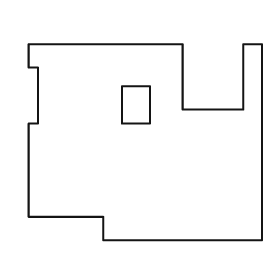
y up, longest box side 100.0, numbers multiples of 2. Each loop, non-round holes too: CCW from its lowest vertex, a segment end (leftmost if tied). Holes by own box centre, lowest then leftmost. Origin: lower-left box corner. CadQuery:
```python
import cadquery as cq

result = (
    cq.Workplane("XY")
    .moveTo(32.0, 0.0)
    .lineTo(100.0, 0.0)
    .lineTo(100.0, 84.0)
    .lineTo(92.0, 84.0)
    .lineTo(92.0, 56.0)
    .lineTo(66.0, 56.0)
    .lineTo(66.0, 84.0)
    .lineTo(0.0, 84.0)
    .lineTo(0.0, 74.0)
    .lineTo(4.0, 74.0)
    .lineTo(4.0, 50.0)
    .lineTo(0.0, 50.0)
    .lineTo(0.0, 10.0)
    .lineTo(32.0, 10.0)
    .close()
    .moveTo(40.0, 50.0)
    .lineTo(52.0, 50.0)
    .lineTo(52.0, 66.0)
    .lineTo(40.0, 66.0)
    .close()
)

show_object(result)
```